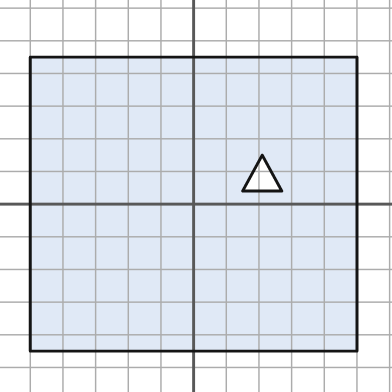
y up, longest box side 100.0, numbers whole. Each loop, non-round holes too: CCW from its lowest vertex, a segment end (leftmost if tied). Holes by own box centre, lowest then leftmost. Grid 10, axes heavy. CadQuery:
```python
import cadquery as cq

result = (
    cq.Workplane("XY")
    .moveTo(-50.0, -45.0)
    .lineTo(50.0, -45.0)
    .lineTo(50.0, 45.0)
    .lineTo(-50.0, 45.0)
    .close()
    .moveTo(15.0, 4.0)
    .lineTo(27.0, 4.0)
    .lineTo(21.0, 15.0)
    .close()
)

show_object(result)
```